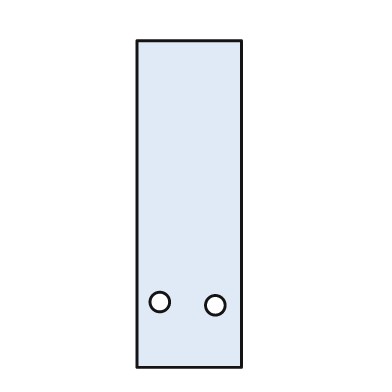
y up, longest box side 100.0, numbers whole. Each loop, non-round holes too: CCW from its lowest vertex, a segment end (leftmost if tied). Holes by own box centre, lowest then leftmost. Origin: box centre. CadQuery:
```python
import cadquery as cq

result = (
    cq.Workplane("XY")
    .moveTo(-16.0, -50.0)
    .lineTo(16.0, -50.0)
    .lineTo(16.0, 50.0)
    .lineTo(-16.0, 50.0)
    .close()
    .moveTo(8.0, -31.0)
    .circle(3.0)
    .moveTo(-9.0, -30.0)
    .circle(3.0)
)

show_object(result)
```